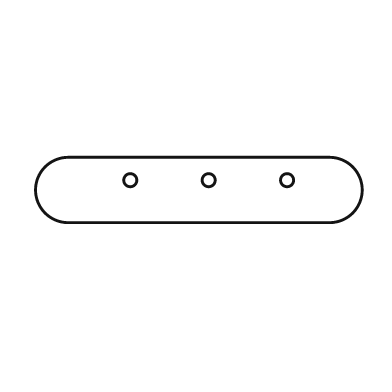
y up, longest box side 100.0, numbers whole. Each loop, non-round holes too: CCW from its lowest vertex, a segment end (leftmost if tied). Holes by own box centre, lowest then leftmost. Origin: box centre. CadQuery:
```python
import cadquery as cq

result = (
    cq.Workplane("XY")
    .moveTo(-40.0, -10.0)
    .lineTo(40.0, -10.0)
    .threePointArc((50.0, 0.0), (40.0, 10.0))
    .lineTo(-40.0, 10.0)
    .threePointArc((-50.0, 0.0), (-40.0, -10.0))
    .close()
    .moveTo(-21.0, 3.0)
    .circle(2.0)
    .moveTo(3.0, 3.0)
    .circle(2.0)
    .moveTo(27.0, 3.0)
    .circle(2.0)
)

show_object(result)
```